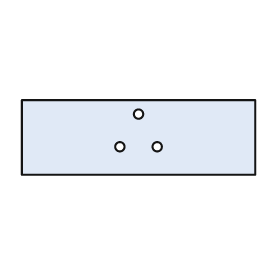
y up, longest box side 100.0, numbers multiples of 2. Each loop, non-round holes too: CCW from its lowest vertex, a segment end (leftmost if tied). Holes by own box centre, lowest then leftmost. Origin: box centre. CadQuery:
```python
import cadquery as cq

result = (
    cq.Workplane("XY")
    .moveTo(-50.0, -16.0)
    .lineTo(50.0, -16.0)
    .lineTo(50.0, 16.0)
    .lineTo(-50.0, 16.0)
    .close()
    .moveTo(-8.0, -4.0)
    .circle(2.0)
    .moveTo(8.0, -4.0)
    .circle(2.0)
    .moveTo(0.0, 10.0)
    .circle(2.0)
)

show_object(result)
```